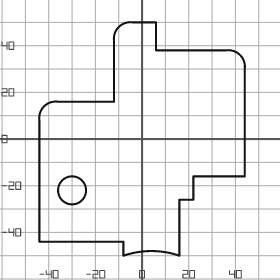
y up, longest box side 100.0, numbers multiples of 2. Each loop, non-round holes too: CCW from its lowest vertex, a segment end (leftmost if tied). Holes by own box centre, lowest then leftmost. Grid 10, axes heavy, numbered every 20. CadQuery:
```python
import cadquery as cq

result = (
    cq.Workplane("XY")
    .moveTo(-8.0, -50.0)
    .threePointArc((4.0, -48.0), (16.0, -50.0))
    .lineTo(16.0, -26.0)
    .lineTo(22.0, -26.0)
    .lineTo(22.0, -16.0)
    .lineTo(44.0, -16.0)
    .lineTo(44.0, 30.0)
    .threePointArc((42.0, 36.0), (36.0, 38.0))
    .lineTo(6.0, 38.0)
    .lineTo(6.0, 50.0)
    .lineTo(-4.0, 50.0)
    .threePointArc((-10.0, 48.0), (-12.0, 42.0))
    .lineTo(-12.0, 16.0)
    .lineTo(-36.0, 16.0)
    .threePointArc((-42.0, 14.0), (-44.0, 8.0))
    .lineTo(-44.0, -44.0)
    .lineTo(-8.0, -44.0)
    .close()
    .moveTo(-30.0, -22.0)
    .circle(6.0)
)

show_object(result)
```